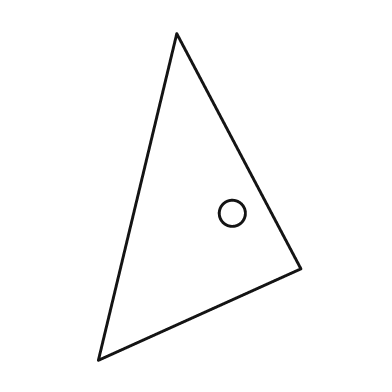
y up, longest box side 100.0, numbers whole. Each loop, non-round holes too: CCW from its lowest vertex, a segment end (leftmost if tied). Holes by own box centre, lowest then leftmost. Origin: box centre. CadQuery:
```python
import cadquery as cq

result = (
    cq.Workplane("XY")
    .moveTo(-31.0, -50.0)
    .lineTo(31.0, -22.0)
    .lineTo(-7.0, 50.0)
    .close()
    .moveTo(10.0, -5.0)
    .circle(4.0)
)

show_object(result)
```